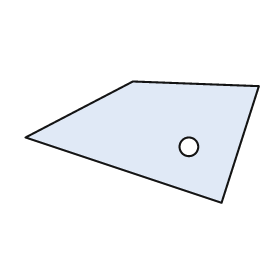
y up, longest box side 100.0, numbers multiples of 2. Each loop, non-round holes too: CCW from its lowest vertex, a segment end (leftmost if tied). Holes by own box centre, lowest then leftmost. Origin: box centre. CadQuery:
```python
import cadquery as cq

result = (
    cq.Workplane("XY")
    .moveTo(34.0, -26.0)
    .lineTo(50.0, 24.0)
    .lineTo(-4.0, 26.0)
    .lineTo(-50.0, 2.0)
    .close()
    .moveTo(20.0, -2.0)
    .circle(4.0)
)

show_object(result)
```